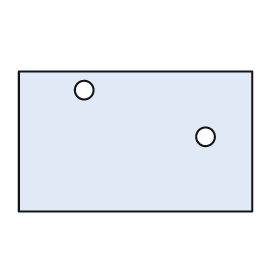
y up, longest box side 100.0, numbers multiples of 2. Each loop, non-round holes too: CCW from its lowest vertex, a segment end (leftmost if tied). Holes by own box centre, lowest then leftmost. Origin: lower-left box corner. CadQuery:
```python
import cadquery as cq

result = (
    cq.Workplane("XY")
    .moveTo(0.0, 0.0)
    .lineTo(100.0, 0.0)
    .lineTo(100.0, 60.0)
    .lineTo(0.0, 60.0)
    .close()
    .moveTo(80.0, 32.0)
    .circle(4.0)
    .moveTo(28.0, 52.0)
    .circle(4.0)
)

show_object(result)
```